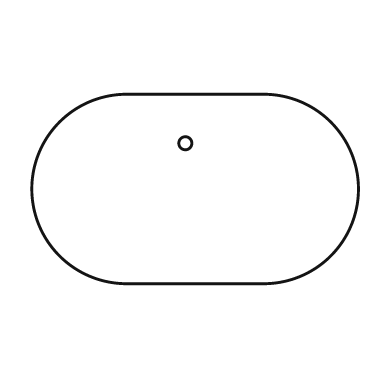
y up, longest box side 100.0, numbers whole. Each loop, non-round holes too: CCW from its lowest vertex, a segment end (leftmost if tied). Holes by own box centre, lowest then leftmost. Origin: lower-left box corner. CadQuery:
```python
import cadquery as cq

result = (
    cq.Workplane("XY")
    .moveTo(29.0, 0.0)
    .lineTo(71.0, 0.0)
    .threePointArc((100.0, 29.0), (71.0, 58.0))
    .lineTo(29.0, 58.0)
    .threePointArc((0.0, 29.0), (29.0, 0.0))
    .close()
    .moveTo(47.0, 43.0)
    .circle(2.0)
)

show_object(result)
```